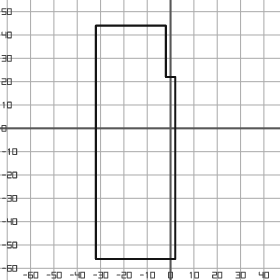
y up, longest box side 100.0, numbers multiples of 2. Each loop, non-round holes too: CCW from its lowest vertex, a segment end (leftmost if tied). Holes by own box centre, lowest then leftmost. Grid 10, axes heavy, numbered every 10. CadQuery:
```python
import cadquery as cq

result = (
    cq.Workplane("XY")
    .moveTo(-32.0, -56.0)
    .lineTo(2.0, -56.0)
    .lineTo(2.0, 22.0)
    .lineTo(-2.0, 22.0)
    .lineTo(-2.0, 44.0)
    .lineTo(-32.0, 44.0)
    .close()
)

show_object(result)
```